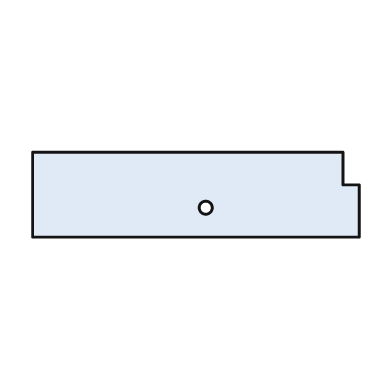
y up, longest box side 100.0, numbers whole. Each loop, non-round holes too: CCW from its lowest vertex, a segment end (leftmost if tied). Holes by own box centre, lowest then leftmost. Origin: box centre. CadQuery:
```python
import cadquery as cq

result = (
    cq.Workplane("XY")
    .moveTo(-50.0, -13.0)
    .lineTo(50.0, -13.0)
    .lineTo(50.0, 3.0)
    .lineTo(45.0, 3.0)
    .lineTo(45.0, 13.0)
    .lineTo(-50.0, 13.0)
    .close()
    .moveTo(3.0, -4.0)
    .circle(2.0)
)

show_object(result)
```